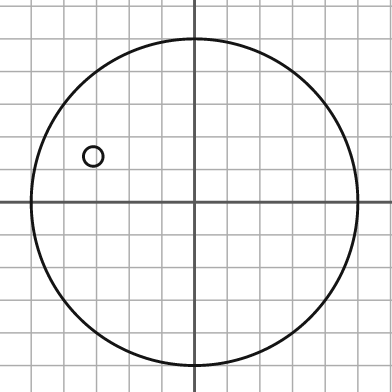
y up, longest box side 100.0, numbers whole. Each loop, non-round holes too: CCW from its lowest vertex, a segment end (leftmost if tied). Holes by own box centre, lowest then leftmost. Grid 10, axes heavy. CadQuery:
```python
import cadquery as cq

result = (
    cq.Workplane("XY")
    .moveTo(0.0, 0.0)
    .circle(50.0)
    .moveTo(-31.0, 14.0)
    .circle(3.0)
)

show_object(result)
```